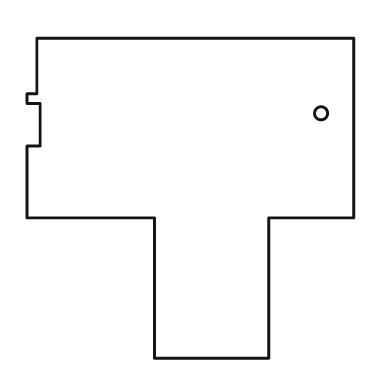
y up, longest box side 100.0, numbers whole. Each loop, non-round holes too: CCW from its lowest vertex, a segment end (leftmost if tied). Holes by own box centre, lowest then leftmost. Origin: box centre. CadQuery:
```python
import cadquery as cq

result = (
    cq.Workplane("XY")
    .moveTo(-11.0, -49.0)
    .lineTo(24.0, -49.0)
    .lineTo(24.0, -6.0)
    .lineTo(50.0, -6.0)
    .lineTo(50.0, 49.0)
    .lineTo(-47.0, 49.0)
    .lineTo(-47.0, 32.0)
    .lineTo(-50.0, 32.0)
    .lineTo(-50.0, 29.0)
    .lineTo(-46.0, 29.0)
    .lineTo(-46.0, 16.0)
    .lineTo(-50.0, 16.0)
    .lineTo(-50.0, -6.0)
    .lineTo(-11.0, -6.0)
    .close()
    .moveTo(40.0, 26.0)
    .circle(2.0)
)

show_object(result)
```